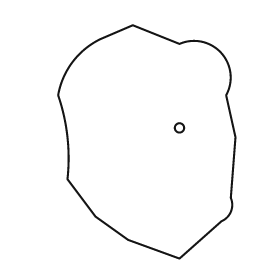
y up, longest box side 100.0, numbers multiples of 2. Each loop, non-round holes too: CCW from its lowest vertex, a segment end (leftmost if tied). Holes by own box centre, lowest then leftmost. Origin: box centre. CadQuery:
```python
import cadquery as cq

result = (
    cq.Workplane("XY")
    .moveTo(14.0, -50.0)
    .lineTo(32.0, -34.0)
    .threePointArc((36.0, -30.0), (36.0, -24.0))
    .lineTo(38.0, 2.0)
    .lineTo(34.0, 20.0)
    .threePointArc((32.0, 38.0), (14.0, 42.0))
    .lineTo(-6.0, 50.0)
    .lineTo(-20.0, 44.0)
    .threePointArc((-32.0, 34.0), (-38.0, 20.0))
    .threePointArc((-34.0, 2.0), (-34.0, -16.0))
    .lineTo(-22.0, -32.0)
    .lineTo(-8.0, -42.0)
    .close()
    .moveTo(14.0, 6.0)
    .circle(2.0)
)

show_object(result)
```